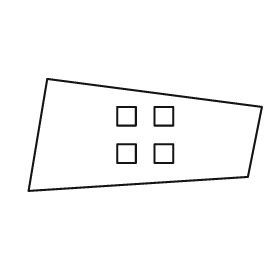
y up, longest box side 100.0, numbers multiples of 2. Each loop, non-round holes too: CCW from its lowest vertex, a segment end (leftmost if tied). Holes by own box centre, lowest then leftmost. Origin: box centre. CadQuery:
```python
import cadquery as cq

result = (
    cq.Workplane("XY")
    .moveTo(-50.0, -24.0)
    .lineTo(44.0, -18.0)
    .lineTo(50.0, 12.0)
    .lineTo(-42.0, 24.0)
    .close()
    .moveTo(-12.0, -12.0)
    .lineTo(-4.0, -12.0)
    .lineTo(-4.0, -4.0)
    .lineTo(-12.0, -4.0)
    .close()
    .moveTo(4.0, -12.0)
    .lineTo(12.0, -12.0)
    .lineTo(12.0, -4.0)
    .lineTo(4.0, -4.0)
    .close()
    .moveTo(-12.0, 4.0)
    .lineTo(-4.0, 4.0)
    .lineTo(-4.0, 12.0)
    .lineTo(-12.0, 12.0)
    .close()
    .moveTo(4.0, 4.0)
    .lineTo(12.0, 4.0)
    .lineTo(12.0, 12.0)
    .lineTo(4.0, 12.0)
    .close()
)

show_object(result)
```